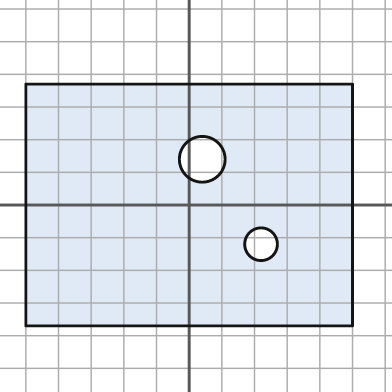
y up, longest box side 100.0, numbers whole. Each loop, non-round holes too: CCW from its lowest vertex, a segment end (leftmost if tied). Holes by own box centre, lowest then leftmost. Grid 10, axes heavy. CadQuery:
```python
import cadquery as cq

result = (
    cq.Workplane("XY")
    .moveTo(-50.0, -37.0)
    .lineTo(50.0, -37.0)
    .lineTo(50.0, 37.0)
    .lineTo(-50.0, 37.0)
    .close()
    .moveTo(22.0, -12.0)
    .circle(5.0)
    .moveTo(4.0, 14.0)
    .circle(7.0)
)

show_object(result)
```